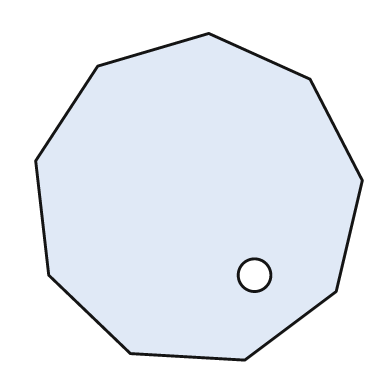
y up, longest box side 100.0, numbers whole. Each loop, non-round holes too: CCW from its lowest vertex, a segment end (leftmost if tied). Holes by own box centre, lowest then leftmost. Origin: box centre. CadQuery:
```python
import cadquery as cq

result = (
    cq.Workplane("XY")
    .moveTo(14.0, -50.0)
    .lineTo(42.0, -29.0)
    .lineTo(50.0, 5.0)
    .lineTo(34.0, 36.0)
    .lineTo(3.0, 50.0)
    .lineTo(-31.0, 40.0)
    .lineTo(-50.0, 11.0)
    .lineTo(-46.0, -24.0)
    .lineTo(-21.0, -48.0)
    .close()
    .moveTo(17.0, -24.0)
    .circle(5.0)
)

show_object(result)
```